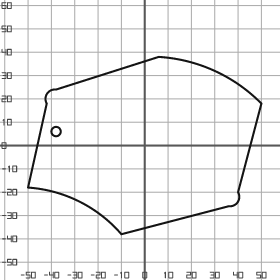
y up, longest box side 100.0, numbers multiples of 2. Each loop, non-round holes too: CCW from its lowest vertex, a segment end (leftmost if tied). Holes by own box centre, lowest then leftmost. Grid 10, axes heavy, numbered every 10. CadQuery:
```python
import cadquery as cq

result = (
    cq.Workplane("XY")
    .moveTo(-10.0, -38.0)
    .lineTo(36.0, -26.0)
    .threePointArc((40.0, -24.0), (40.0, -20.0))
    .lineTo(50.0, 18.0)
    .threePointArc((30.0, 32.0), (6.0, 38.0))
    .lineTo(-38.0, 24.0)
    .threePointArc((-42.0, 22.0), (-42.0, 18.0))
    .lineTo(-50.0, -18.0)
    .threePointArc((-28.0, -24.0), (-10.0, -38.0))
    .close()
    .moveTo(-38.0, 6.0)
    .circle(2.0)
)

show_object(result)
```